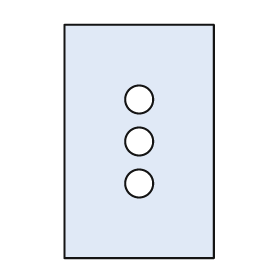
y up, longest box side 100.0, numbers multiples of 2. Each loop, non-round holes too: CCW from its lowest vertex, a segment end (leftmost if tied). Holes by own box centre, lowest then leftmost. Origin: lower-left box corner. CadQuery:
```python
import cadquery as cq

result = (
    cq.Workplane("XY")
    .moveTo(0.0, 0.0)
    .lineTo(64.0, 0.0)
    .lineTo(64.0, 100.0)
    .lineTo(0.0, 100.0)
    .close()
    .moveTo(32.0, 32.0)
    .circle(6.0)
    .moveTo(32.0, 50.0)
    .circle(6.0)
    .moveTo(32.0, 68.0)
    .circle(6.0)
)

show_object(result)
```